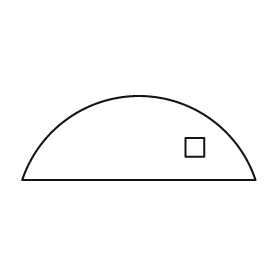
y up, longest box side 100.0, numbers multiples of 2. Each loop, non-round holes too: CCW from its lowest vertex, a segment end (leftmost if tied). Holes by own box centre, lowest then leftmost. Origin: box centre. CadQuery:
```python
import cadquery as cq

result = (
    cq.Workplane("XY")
    .moveTo(-50.0, -18.0)
    .lineTo(50.0, -18.0)
    .threePointArc((0.0, 18.0), (-50.0, -18.0))
    .close()
    .moveTo(20.0, -8.0)
    .lineTo(28.0, -8.0)
    .lineTo(28.0, 0.0)
    .lineTo(20.0, 0.0)
    .close()
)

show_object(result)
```